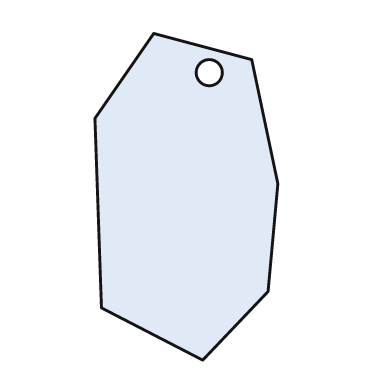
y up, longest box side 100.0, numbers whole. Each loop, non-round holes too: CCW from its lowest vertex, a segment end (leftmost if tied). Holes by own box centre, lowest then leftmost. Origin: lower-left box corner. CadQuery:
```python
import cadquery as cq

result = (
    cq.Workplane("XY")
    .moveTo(33.0, 0.0)
    .lineTo(53.0, 21.0)
    .lineTo(56.0, 54.0)
    .lineTo(48.0, 92.0)
    .lineTo(18.0, 100.0)
    .lineTo(0.0, 74.0)
    .lineTo(2.0, 16.0)
    .close()
    .moveTo(35.0, 88.0)
    .circle(4.0)
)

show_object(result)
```